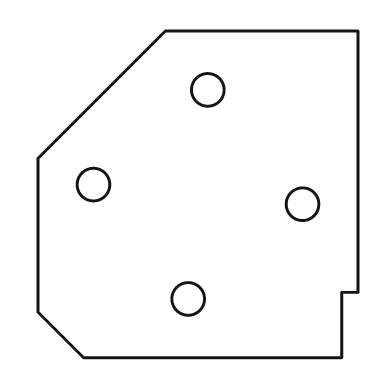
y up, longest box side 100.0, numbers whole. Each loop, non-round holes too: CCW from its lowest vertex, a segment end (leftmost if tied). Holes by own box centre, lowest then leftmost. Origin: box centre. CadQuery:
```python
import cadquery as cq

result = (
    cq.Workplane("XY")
    .moveTo(-35.0, -50.0)
    .lineTo(44.0, -50.0)
    .lineTo(44.0, -30.0)
    .lineTo(49.0, -30.0)
    .lineTo(49.0, 50.0)
    .lineTo(-10.0, 50.0)
    .lineTo(-49.0, 11.0)
    .lineTo(-49.0, -36.0)
    .close()
    .moveTo(-3.0, -32.0)
    .circle(5.0)
    .moveTo(32.0, -3.0)
    .circle(5.0)
    .moveTo(-32.0, 3.0)
    .circle(5.0)
    .moveTo(3.0, 32.0)
    .circle(5.0)
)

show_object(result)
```